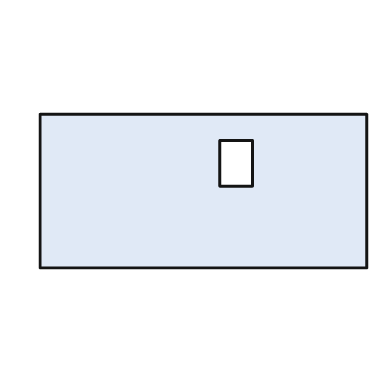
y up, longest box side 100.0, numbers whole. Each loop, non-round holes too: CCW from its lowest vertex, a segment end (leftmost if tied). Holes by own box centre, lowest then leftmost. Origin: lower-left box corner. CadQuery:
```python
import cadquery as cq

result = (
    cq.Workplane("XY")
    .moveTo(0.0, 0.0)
    .lineTo(100.0, 0.0)
    .lineTo(100.0, 47.0)
    .lineTo(0.0, 47.0)
    .close()
    .moveTo(55.0, 25.0)
    .lineTo(65.0, 25.0)
    .lineTo(65.0, 39.0)
    .lineTo(55.0, 39.0)
    .close()
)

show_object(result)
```